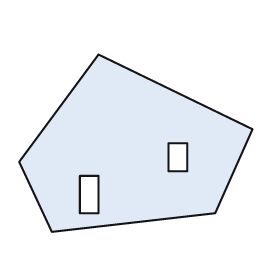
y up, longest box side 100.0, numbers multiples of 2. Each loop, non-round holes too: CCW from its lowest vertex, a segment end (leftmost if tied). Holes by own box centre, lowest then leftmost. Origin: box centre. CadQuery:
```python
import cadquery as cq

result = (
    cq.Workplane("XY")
    .moveTo(-36.0, -38.0)
    .lineTo(34.0, -30.0)
    .lineTo(50.0, 6.0)
    .lineTo(-16.0, 38.0)
    .lineTo(-50.0, -8.0)
    .close()
    .moveTo(-24.0, -30.0)
    .lineTo(-16.0, -30.0)
    .lineTo(-16.0, -14.0)
    .lineTo(-24.0, -14.0)
    .close()
    .moveTo(14.0, -12.0)
    .lineTo(22.0, -12.0)
    .lineTo(22.0, 0.0)
    .lineTo(14.0, 0.0)
    .close()
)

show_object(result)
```